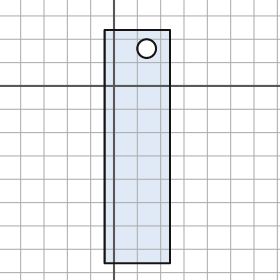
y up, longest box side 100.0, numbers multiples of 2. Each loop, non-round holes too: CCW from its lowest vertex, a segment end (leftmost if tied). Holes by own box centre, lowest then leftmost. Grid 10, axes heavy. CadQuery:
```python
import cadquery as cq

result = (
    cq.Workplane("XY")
    .moveTo(-4.0, -76.0)
    .lineTo(24.0, -76.0)
    .lineTo(24.0, 24.0)
    .lineTo(-4.0, 24.0)
    .close()
    .moveTo(14.0, 16.0)
    .circle(4.0)
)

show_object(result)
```